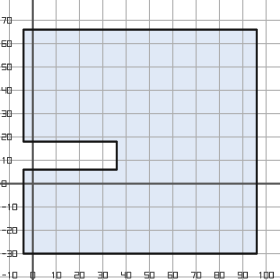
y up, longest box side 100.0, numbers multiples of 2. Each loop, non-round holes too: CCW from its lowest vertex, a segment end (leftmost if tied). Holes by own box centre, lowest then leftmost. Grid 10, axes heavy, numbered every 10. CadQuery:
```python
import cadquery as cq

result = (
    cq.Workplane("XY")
    .moveTo(-4.0, -30.0)
    .lineTo(96.0, -30.0)
    .lineTo(96.0, 66.0)
    .lineTo(-4.0, 66.0)
    .lineTo(-4.0, 18.0)
    .lineTo(36.0, 18.0)
    .lineTo(36.0, 6.0)
    .lineTo(-4.0, 6.0)
    .close()
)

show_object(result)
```